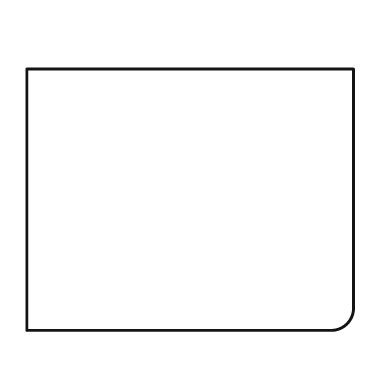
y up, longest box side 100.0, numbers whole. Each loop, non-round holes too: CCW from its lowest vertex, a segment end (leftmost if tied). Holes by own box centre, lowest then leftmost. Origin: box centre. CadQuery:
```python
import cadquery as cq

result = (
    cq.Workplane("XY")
    .moveTo(-50.0, -40.0)
    .lineTo(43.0, -40.0)
    .threePointArc((48.0, -38.0), (50.0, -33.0))
    .lineTo(50.0, 40.0)
    .lineTo(-50.0, 40.0)
    .close()
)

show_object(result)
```